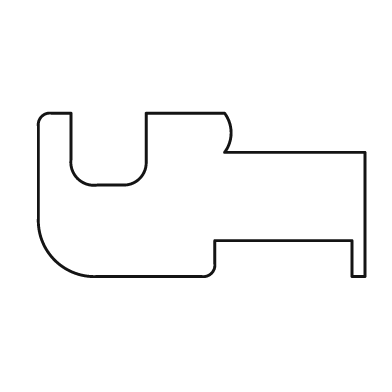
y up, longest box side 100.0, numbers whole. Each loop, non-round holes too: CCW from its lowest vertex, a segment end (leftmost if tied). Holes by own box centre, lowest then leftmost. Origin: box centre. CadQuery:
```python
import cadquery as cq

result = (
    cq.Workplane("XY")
    .moveTo(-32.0, -25.0)
    .lineTo(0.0, -25.0)
    .threePointArc((3.0, -24.0), (4.0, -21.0))
    .lineTo(4.0, -14.0)
    .lineTo(46.0, -14.0)
    .lineTo(46.0, -25.0)
    .lineTo(50.0, -25.0)
    .lineTo(50.0, 13.0)
    .lineTo(7.0, 13.0)
    .threePointArc((9.0, 19.0), (7.0, 25.0))
    .lineTo(-17.0, 25.0)
    .lineTo(-17.0, 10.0)
    .threePointArc((-19.0, 5.0), (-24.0, 3.0))
    .lineTo(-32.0, 3.0)
    .threePointArc((-38.0, 5.0), (-40.0, 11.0))
    .lineTo(-40.0, 25.0)
    .lineTo(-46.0, 25.0)
    .threePointArc((-49.0, 24.0), (-50.0, 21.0))
    .lineTo(-50.0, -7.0)
    .threePointArc((-45.0, -20.0), (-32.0, -25.0))
    .close()
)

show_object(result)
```